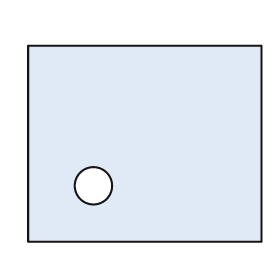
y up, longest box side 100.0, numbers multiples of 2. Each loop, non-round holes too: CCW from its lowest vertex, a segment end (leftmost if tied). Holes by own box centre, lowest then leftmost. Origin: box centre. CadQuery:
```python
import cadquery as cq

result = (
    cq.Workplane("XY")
    .moveTo(-50.0, -42.0)
    .lineTo(50.0, -42.0)
    .lineTo(50.0, 42.0)
    .lineTo(-50.0, 42.0)
    .close()
    .moveTo(-22.0, -18.0)
    .circle(8.0)
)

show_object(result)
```